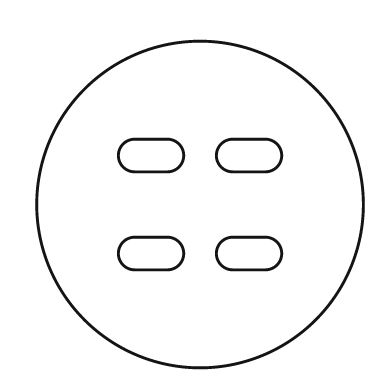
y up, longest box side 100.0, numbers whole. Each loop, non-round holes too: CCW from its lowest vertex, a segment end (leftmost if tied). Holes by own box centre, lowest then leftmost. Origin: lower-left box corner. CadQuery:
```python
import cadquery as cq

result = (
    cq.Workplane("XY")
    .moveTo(50.0, 50.0)
    .circle(50.0)
    .moveTo(30.0, 30.0)
    .lineTo(40.0, 30.0)
    .threePointArc((45.0, 35.0), (40.0, 40.0))
    .lineTo(30.0, 40.0)
    .threePointArc((25.0, 35.0), (30.0, 30.0))
    .close()
    .moveTo(60.0, 30.0)
    .lineTo(70.0, 30.0)
    .threePointArc((75.0, 35.0), (70.0, 40.0))
    .lineTo(60.0, 40.0)
    .threePointArc((55.0, 35.0), (60.0, 30.0))
    .close()
    .moveTo(30.0, 60.0)
    .lineTo(40.0, 60.0)
    .threePointArc((45.0, 65.0), (40.0, 70.0))
    .lineTo(30.0, 70.0)
    .threePointArc((25.0, 65.0), (30.0, 60.0))
    .close()
    .moveTo(60.0, 60.0)
    .lineTo(70.0, 60.0)
    .threePointArc((75.0, 65.0), (70.0, 70.0))
    .lineTo(60.0, 70.0)
    .threePointArc((55.0, 65.0), (60.0, 60.0))
    .close()
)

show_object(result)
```